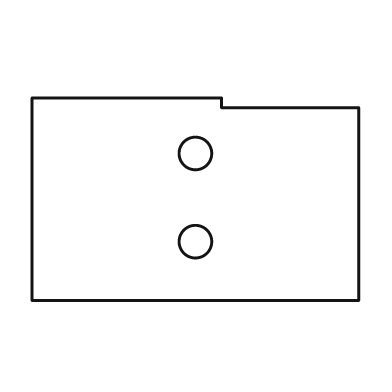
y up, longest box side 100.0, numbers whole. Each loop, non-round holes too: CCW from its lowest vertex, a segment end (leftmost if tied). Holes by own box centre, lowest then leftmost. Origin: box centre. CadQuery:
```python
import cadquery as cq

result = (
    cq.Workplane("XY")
    .moveTo(-50.0, -31.0)
    .lineTo(50.0, -31.0)
    .lineTo(50.0, 28.0)
    .lineTo(8.0, 28.0)
    .lineTo(8.0, 31.0)
    .lineTo(-50.0, 31.0)
    .close()
    .moveTo(0.0, -13.0)
    .circle(5.0)
    .moveTo(0.0, 14.0)
    .circle(5.0)
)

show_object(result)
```